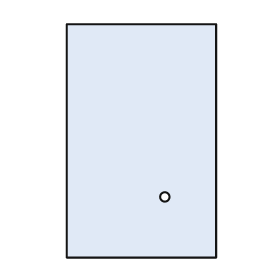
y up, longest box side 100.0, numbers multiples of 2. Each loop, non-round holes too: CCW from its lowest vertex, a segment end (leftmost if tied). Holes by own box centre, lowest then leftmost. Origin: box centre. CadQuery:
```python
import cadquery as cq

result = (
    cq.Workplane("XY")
    .moveTo(-32.0, -50.0)
    .lineTo(32.0, -50.0)
    .lineTo(32.0, 50.0)
    .lineTo(-32.0, 50.0)
    .close()
    .moveTo(10.0, -24.0)
    .circle(2.0)
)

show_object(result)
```